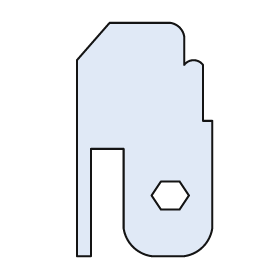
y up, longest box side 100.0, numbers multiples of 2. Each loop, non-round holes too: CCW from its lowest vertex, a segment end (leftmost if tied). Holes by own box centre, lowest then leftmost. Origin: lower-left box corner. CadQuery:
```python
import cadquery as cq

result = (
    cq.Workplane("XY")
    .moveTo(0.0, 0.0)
    .lineTo(6.0, 0.0)
    .lineTo(6.0, 46.0)
    .lineTo(20.0, 46.0)
    .lineTo(20.0, 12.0)
    .threePointArc((24.0, 4.0), (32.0, 0.0))
    .lineTo(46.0, 0.0)
    .threePointArc((54.0, 4.0), (58.0, 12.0))
    .lineTo(58.0, 58.0)
    .lineTo(54.0, 58.0)
    .lineTo(54.0, 82.0)
    .threePointArc((50.0, 84.0), (46.0, 82.0))
    .lineTo(46.0, 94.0)
    .threePointArc((44.0, 98.0), (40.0, 100.0))
    .lineTo(14.0, 100.0)
    .lineTo(0.0, 84.0)
    .close()
    .moveTo(36.0, 20.0)
    .lineTo(44.0, 20.0)
    .lineTo(48.0, 26.0)
    .lineTo(44.0, 32.0)
    .lineTo(36.0, 32.0)
    .lineTo(32.0, 26.0)
    .close()
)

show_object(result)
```